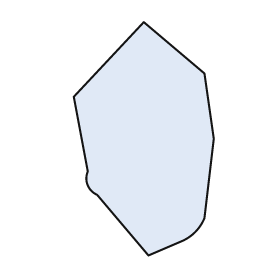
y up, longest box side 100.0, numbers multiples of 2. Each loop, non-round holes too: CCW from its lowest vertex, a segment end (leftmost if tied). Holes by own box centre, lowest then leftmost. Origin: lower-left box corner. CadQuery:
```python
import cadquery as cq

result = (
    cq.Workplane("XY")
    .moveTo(32.0, 0.0)
    .lineTo(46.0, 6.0)
    .threePointArc((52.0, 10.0), (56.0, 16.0))
    .lineTo(60.0, 50.0)
    .lineTo(56.0, 78.0)
    .lineTo(30.0, 100.0)
    .lineTo(0.0, 68.0)
    .lineTo(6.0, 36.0)
    .threePointArc((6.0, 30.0), (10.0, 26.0))
    .close()
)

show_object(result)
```